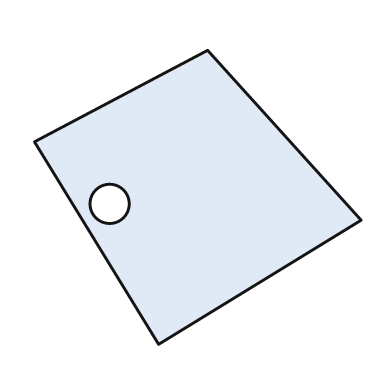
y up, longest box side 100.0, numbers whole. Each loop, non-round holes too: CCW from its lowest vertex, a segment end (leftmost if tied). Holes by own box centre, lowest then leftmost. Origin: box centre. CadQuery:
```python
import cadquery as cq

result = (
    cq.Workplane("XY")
    .moveTo(-12.0, -45.0)
    .lineTo(50.0, -7.0)
    .lineTo(3.0, 45.0)
    .lineTo(-50.0, 17.0)
    .close()
    .moveTo(-27.0, -2.0)
    .circle(6.0)
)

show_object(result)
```